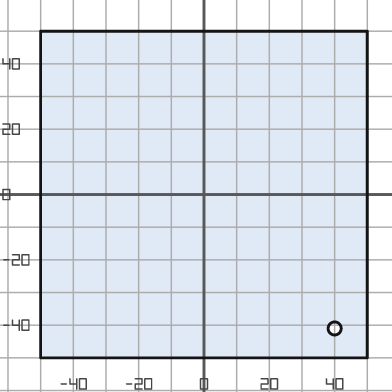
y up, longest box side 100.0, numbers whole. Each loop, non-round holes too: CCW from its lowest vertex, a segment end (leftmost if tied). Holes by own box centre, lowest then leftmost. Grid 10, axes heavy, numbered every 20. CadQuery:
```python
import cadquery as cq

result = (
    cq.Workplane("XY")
    .moveTo(-50.0, -50.0)
    .lineTo(50.0, -50.0)
    .lineTo(50.0, 50.0)
    .lineTo(-50.0, 50.0)
    .close()
    .moveTo(40.0, -41.0)
    .circle(2.0)
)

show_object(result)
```